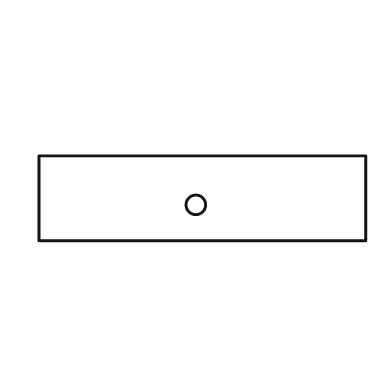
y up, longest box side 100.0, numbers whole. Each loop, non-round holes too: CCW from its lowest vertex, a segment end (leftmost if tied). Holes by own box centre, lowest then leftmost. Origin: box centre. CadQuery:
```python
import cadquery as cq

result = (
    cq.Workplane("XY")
    .moveTo(-50.0, -13.0)
    .lineTo(50.0, -13.0)
    .lineTo(50.0, 13.0)
    .lineTo(-50.0, 13.0)
    .close()
    .moveTo(-2.0, -2.0)
    .circle(3.0)
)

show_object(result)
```